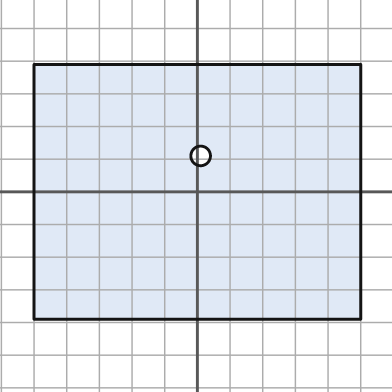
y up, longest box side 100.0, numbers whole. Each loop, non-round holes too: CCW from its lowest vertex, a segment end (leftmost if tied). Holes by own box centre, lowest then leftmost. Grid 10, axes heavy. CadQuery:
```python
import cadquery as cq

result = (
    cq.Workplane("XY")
    .moveTo(-50.0, -39.0)
    .lineTo(50.0, -39.0)
    .lineTo(50.0, 39.0)
    .lineTo(-50.0, 39.0)
    .close()
    .moveTo(1.0, 11.0)
    .circle(3.0)
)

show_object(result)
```